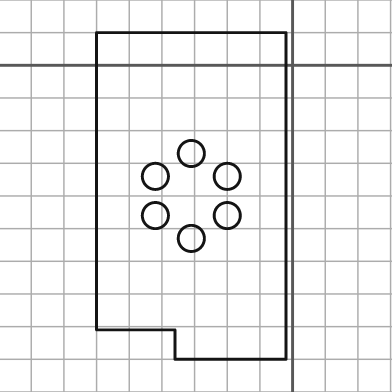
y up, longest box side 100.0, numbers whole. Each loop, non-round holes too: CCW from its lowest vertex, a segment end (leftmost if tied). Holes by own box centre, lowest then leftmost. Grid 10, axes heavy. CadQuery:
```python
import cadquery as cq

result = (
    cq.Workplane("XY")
    .moveTo(-36.0, -90.0)
    .lineTo(-2.0, -90.0)
    .lineTo(-2.0, 10.0)
    .lineTo(-60.0, 10.0)
    .lineTo(-60.0, -81.0)
    .lineTo(-36.0, -81.0)
    .close()
    .moveTo(-31.0, -53.0)
    .circle(4.0)
    .moveTo(-42.0, -46.0)
    .circle(4.0)
    .moveTo(-20.0, -46.0)
    .circle(4.0)
    .moveTo(-42.0, -34.0)
    .circle(4.0)
    .moveTo(-20.0, -34.0)
    .circle(4.0)
    .moveTo(-31.0, -27.0)
    .circle(4.0)
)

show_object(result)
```